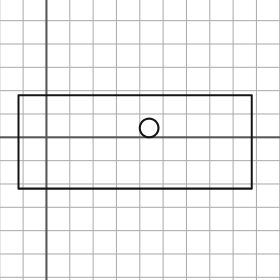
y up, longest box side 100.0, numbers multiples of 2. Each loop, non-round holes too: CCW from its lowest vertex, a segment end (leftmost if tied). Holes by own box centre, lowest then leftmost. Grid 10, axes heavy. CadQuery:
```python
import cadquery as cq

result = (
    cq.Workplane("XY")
    .moveTo(-12.0, -22.0)
    .lineTo(88.0, -22.0)
    .lineTo(88.0, 18.0)
    .lineTo(-12.0, 18.0)
    .close()
    .moveTo(44.0, 4.0)
    .circle(4.0)
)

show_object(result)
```